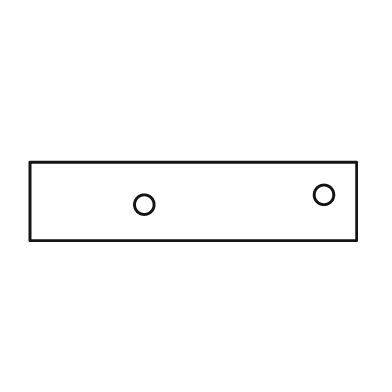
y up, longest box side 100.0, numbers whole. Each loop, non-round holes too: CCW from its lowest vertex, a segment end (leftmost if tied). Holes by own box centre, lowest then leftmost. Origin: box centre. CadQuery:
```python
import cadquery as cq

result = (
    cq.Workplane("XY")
    .moveTo(-50.0, -12.0)
    .lineTo(50.0, -12.0)
    .lineTo(50.0, 12.0)
    .lineTo(-50.0, 12.0)
    .close()
    .moveTo(-15.0, -1.0)
    .circle(3.0)
    .moveTo(40.0, 2.0)
    .circle(3.0)
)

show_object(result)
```